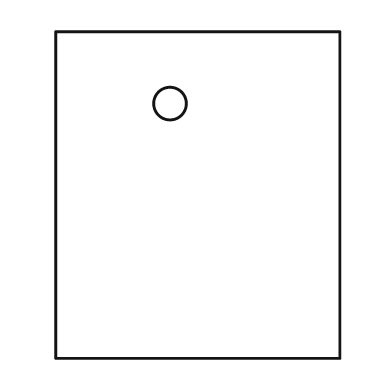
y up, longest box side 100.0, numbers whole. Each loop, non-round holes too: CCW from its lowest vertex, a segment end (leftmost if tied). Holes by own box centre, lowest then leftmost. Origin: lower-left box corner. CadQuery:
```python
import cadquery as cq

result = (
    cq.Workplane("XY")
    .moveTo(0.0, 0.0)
    .lineTo(87.0, 0.0)
    .lineTo(87.0, 100.0)
    .lineTo(0.0, 100.0)
    .close()
    .moveTo(35.0, 78.0)
    .circle(5.0)
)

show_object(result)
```